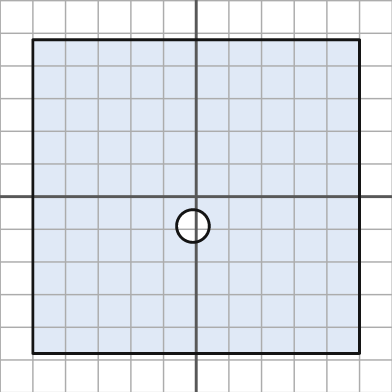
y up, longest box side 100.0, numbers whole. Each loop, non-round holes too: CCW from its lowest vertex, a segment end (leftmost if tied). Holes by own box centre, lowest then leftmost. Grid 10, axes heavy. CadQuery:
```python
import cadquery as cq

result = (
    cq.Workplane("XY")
    .moveTo(-50.0, -48.0)
    .lineTo(50.0, -48.0)
    .lineTo(50.0, 48.0)
    .lineTo(-50.0, 48.0)
    .close()
    .moveTo(-1.0, -9.0)
    .circle(5.0)
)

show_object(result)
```